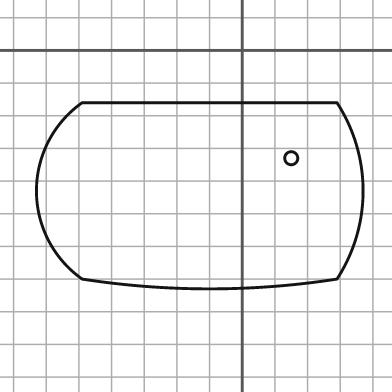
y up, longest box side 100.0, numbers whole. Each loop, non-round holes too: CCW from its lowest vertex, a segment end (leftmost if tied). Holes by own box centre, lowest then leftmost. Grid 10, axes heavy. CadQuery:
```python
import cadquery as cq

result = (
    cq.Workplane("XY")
    .moveTo(-49.0, -70.0)
    .threePointArc((-10.0, -73.0), (29.0, -70.0))
    .threePointArc((37.0, -43.0), (29.0, -16.0))
    .lineTo(-49.0, -16.0)
    .threePointArc((-63.0, -43.0), (-49.0, -70.0))
    .close()
    .moveTo(15.0, -33.0)
    .circle(2.0)
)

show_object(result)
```